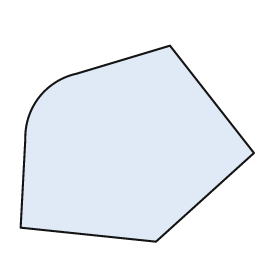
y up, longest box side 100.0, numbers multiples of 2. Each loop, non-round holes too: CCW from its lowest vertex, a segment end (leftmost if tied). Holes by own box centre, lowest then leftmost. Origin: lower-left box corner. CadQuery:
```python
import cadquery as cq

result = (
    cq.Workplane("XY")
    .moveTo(58.0, 0.0)
    .lineTo(100.0, 38.0)
    .lineTo(64.0, 84.0)
    .lineTo(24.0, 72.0)
    .threePointArc((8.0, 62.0), (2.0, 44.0))
    .lineTo(0.0, 6.0)
    .close()
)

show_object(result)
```